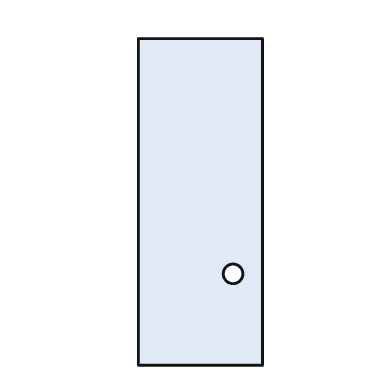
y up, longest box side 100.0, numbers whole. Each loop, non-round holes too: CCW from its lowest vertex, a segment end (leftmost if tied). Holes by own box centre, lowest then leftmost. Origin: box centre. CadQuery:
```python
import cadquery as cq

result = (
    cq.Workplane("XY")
    .moveTo(-19.0, -50.0)
    .lineTo(19.0, -50.0)
    .lineTo(19.0, 50.0)
    .lineTo(-19.0, 50.0)
    .close()
    .moveTo(10.0, -22.0)
    .circle(3.0)
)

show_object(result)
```